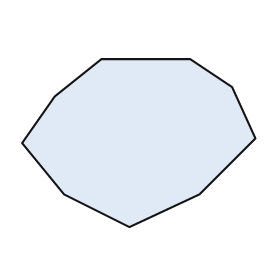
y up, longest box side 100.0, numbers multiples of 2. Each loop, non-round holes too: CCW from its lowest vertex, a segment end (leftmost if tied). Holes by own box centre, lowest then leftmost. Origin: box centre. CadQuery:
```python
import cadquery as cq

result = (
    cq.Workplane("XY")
    .moveTo(-4.0, -36.0)
    .lineTo(26.0, -22.0)
    .lineTo(50.0, 2.0)
    .lineTo(40.0, 24.0)
    .lineTo(22.0, 36.0)
    .lineTo(-16.0, 36.0)
    .lineTo(-36.0, 20.0)
    .lineTo(-50.0, 0.0)
    .lineTo(-32.0, -22.0)
    .close()
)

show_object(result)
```